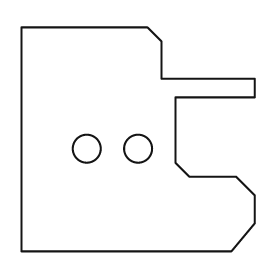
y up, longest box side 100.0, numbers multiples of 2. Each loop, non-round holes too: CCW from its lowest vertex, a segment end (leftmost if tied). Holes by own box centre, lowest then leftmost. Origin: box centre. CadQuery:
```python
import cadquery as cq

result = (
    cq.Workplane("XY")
    .moveTo(-50.0, -48.0)
    .lineTo(40.0, -48.0)
    .lineTo(50.0, -36.0)
    .lineTo(50.0, -24.0)
    .lineTo(42.0, -16.0)
    .lineTo(22.0, -16.0)
    .lineTo(16.0, -10.0)
    .lineTo(16.0, 18.0)
    .lineTo(50.0, 18.0)
    .lineTo(50.0, 26.0)
    .lineTo(10.0, 26.0)
    .lineTo(10.0, 42.0)
    .lineTo(4.0, 48.0)
    .lineTo(-50.0, 48.0)
    .close()
    .moveTo(-22.0, -4.0)
    .circle(6.0)
    .moveTo(0.0, -4.0)
    .circle(6.0)
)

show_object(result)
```